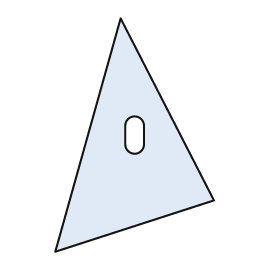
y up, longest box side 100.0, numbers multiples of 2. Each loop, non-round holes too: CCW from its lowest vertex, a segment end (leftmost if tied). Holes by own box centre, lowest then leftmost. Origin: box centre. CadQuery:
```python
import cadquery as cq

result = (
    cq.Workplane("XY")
    .moveTo(-34.0, -50.0)
    .lineTo(34.0, -28.0)
    .lineTo(-6.0, 50.0)
    .close()
    .moveTo(-4.0, -4.0)
    .threePointArc((0.0, -8.0), (4.0, -4.0))
    .lineTo(4.0, 4.0)
    .threePointArc((0.0, 8.0), (-4.0, 4.0))
    .close()
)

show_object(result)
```